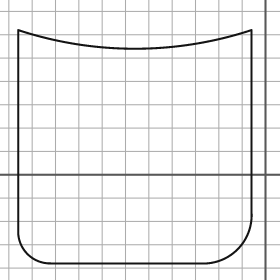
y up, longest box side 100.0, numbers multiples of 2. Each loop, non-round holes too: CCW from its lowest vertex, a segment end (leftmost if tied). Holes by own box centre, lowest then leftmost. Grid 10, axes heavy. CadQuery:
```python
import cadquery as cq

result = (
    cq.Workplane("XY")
    .moveTo(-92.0, -38.0)
    .lineTo(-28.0, -38.0)
    .threePointArc((-12.0, -32.0), (-6.0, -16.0))
    .lineTo(-6.0, 62.0)
    .threePointArc((-56.0, 54.0), (-106.0, 62.0))
    .lineTo(-106.0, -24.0)
    .threePointArc((-102.0, -34.0), (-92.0, -38.0))
    .close()
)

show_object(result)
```